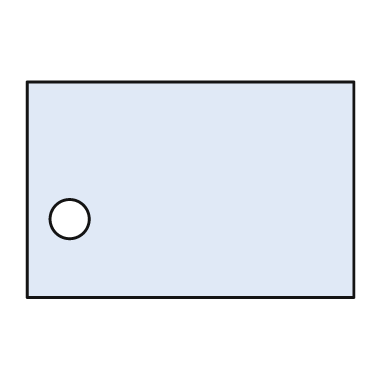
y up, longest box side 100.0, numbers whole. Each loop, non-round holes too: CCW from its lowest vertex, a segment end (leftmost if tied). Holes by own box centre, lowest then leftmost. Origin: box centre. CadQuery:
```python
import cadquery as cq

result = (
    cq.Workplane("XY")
    .moveTo(-50.0, -33.0)
    .lineTo(50.0, -33.0)
    .lineTo(50.0, 33.0)
    .lineTo(-50.0, 33.0)
    .close()
    .moveTo(-37.0, -9.0)
    .circle(6.0)
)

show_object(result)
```